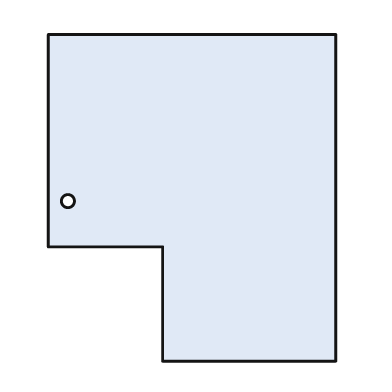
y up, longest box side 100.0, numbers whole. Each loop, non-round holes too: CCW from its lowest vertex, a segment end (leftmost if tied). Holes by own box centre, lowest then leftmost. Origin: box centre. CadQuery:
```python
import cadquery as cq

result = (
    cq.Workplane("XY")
    .moveTo(-9.0, -50.0)
    .lineTo(44.0, -50.0)
    .lineTo(44.0, 50.0)
    .lineTo(-44.0, 50.0)
    .lineTo(-44.0, -15.0)
    .lineTo(-9.0, -15.0)
    .close()
    .moveTo(-38.0, -1.0)
    .circle(2.0)
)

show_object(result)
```